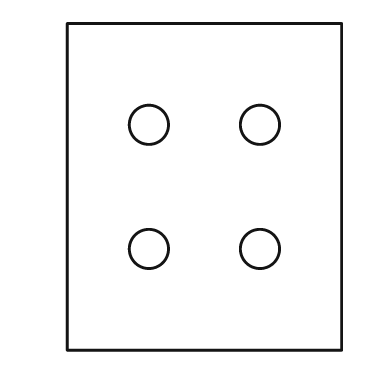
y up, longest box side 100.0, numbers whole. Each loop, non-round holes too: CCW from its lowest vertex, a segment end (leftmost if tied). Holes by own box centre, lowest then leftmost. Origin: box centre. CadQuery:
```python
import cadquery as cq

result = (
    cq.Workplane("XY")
    .moveTo(-42.0, -50.0)
    .lineTo(42.0, -50.0)
    .lineTo(42.0, 50.0)
    .lineTo(-42.0, 50.0)
    .close()
    .moveTo(-17.0, -19.0)
    .circle(6.0)
    .moveTo(17.0, -19.0)
    .circle(6.0)
    .moveTo(-17.0, 19.0)
    .circle(6.0)
    .moveTo(17.0, 19.0)
    .circle(6.0)
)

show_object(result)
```